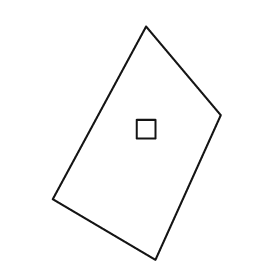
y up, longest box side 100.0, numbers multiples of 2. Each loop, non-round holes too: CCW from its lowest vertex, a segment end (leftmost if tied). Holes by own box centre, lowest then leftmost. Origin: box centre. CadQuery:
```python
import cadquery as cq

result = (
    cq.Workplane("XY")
    .moveTo(8.0, -50.0)
    .lineTo(36.0, 12.0)
    .lineTo(4.0, 50.0)
    .lineTo(-36.0, -24.0)
    .close()
    .moveTo(0.0, 2.0)
    .lineTo(8.0, 2.0)
    .lineTo(8.0, 10.0)
    .lineTo(0.0, 10.0)
    .close()
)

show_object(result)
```